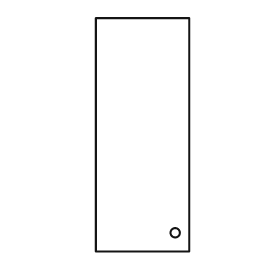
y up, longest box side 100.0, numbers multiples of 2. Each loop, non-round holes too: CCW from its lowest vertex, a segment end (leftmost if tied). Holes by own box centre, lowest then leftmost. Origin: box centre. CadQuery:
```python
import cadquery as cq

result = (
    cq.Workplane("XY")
    .moveTo(-20.0, -50.0)
    .lineTo(20.0, -50.0)
    .lineTo(20.0, 50.0)
    .lineTo(-20.0, 50.0)
    .close()
    .moveTo(14.0, -42.0)
    .circle(2.0)
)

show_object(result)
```